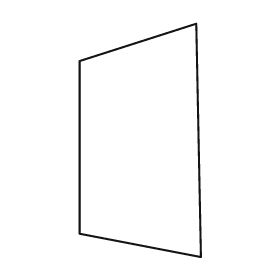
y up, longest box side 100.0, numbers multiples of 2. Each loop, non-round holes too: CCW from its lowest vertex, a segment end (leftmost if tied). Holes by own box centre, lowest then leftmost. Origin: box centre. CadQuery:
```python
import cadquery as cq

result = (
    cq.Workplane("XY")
    .moveTo(26.0, -50.0)
    .lineTo(24.0, 50.0)
    .lineTo(-26.0, 34.0)
    .lineTo(-26.0, -40.0)
    .close()
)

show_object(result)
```